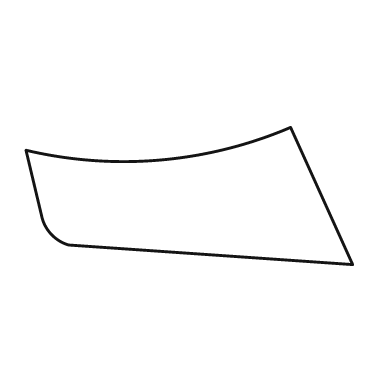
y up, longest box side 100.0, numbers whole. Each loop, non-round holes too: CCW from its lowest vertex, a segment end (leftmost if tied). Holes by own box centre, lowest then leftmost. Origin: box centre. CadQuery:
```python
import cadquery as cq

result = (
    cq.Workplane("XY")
    .moveTo(50.0, -21.0)
    .lineTo(31.0, 21.0)
    .threePointArc((-9.0, 11.0), (-50.0, 14.0))
    .lineTo(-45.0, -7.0)
    .threePointArc((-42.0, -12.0), (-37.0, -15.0))
    .close()
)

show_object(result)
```